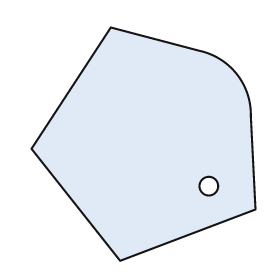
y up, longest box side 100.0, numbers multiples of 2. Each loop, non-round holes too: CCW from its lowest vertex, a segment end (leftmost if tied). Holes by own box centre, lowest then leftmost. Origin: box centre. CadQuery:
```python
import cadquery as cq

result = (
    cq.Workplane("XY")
    .moveTo(-10.0, -50.0)
    .lineTo(48.0, -28.0)
    .lineTo(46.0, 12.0)
    .threePointArc((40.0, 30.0), (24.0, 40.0))
    .lineTo(-14.0, 50.0)
    .lineTo(-48.0, -2.0)
    .close()
    .moveTo(28.0, -18.0)
    .circle(4.0)
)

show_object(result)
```